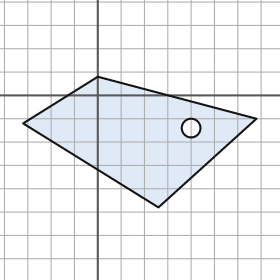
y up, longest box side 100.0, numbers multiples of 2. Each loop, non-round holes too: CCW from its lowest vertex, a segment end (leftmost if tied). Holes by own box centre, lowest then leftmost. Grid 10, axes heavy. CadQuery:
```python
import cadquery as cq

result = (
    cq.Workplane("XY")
    .moveTo(26.0, -48.0)
    .lineTo(68.0, -10.0)
    .lineTo(0.0, 8.0)
    .lineTo(-32.0, -12.0)
    .close()
    .moveTo(40.0, -14.0)
    .circle(4.0)
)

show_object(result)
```